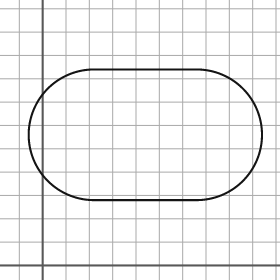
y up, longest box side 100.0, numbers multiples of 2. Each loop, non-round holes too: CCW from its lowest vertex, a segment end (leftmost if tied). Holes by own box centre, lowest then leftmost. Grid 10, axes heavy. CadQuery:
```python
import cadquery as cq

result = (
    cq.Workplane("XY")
    .moveTo(22.0, 28.0)
    .lineTo(66.0, 28.0)
    .threePointArc((94.0, 56.0), (66.0, 84.0))
    .lineTo(22.0, 84.0)
    .threePointArc((-6.0, 56.0), (22.0, 28.0))
    .close()
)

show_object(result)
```